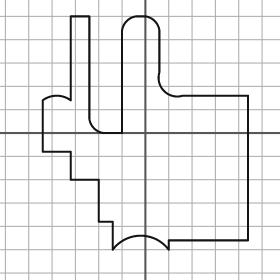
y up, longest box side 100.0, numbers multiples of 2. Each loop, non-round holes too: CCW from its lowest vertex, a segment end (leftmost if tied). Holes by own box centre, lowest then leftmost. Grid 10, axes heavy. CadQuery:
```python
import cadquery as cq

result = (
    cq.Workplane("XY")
    .moveTo(-14.0, -50.0)
    .threePointArc((-2.0, -44.0), (10.0, -50.0))
    .lineTo(10.0, -46.0)
    .lineTo(44.0, -46.0)
    .lineTo(44.0, 16.0)
    .lineTo(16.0, 16.0)
    .threePointArc((8.0, 18.0), (6.0, 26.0))
    .lineTo(6.0, 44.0)
    .threePointArc((4.0, 48.0), (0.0, 50.0))
    .lineTo(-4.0, 50.0)
    .threePointArc((-8.0, 48.0), (-10.0, 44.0))
    .lineTo(-10.0, 0.0)
    .lineTo(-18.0, 0.0)
    .threePointArc((-22.0, 2.0), (-24.0, 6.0))
    .lineTo(-24.0, 50.0)
    .lineTo(-32.0, 50.0)
    .lineTo(-32.0, 14.0)
    .threePointArc((-38.0, 16.0), (-44.0, 14.0))
    .lineTo(-44.0, -8.0)
    .lineTo(-32.0, -8.0)
    .lineTo(-32.0, -20.0)
    .lineTo(-20.0, -20.0)
    .lineTo(-20.0, -38.0)
    .lineTo(-14.0, -38.0)
    .close()
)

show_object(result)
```